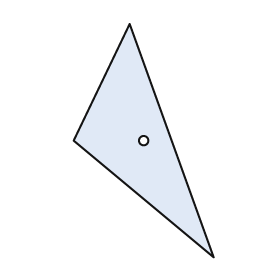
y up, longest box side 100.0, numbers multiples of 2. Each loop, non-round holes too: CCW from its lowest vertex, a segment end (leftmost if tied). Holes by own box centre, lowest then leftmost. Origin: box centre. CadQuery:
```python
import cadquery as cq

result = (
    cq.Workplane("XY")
    .moveTo(30.0, -50.0)
    .lineTo(-6.0, 50.0)
    .lineTo(-30.0, 0.0)
    .close()
    .moveTo(0.0, 0.0)
    .circle(2.0)
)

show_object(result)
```